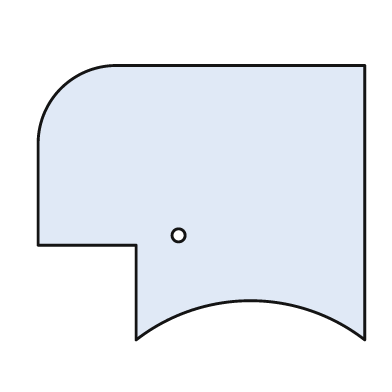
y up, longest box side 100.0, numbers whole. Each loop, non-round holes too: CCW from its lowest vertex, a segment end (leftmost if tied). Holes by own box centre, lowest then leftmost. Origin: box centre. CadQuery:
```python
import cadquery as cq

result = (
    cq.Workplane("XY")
    .moveTo(-20.0, -42.0)
    .threePointArc((15.0, -30.0), (50.0, -42.0))
    .lineTo(50.0, 42.0)
    .lineTo(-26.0, 42.0)
    .threePointArc((-43.0, 35.0), (-50.0, 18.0))
    .lineTo(-50.0, -13.0)
    .lineTo(-20.0, -13.0)
    .close()
    .moveTo(-7.0, -10.0)
    .circle(2.0)
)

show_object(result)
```